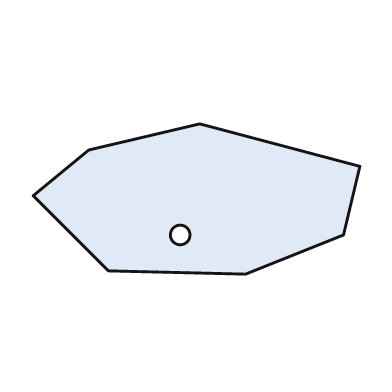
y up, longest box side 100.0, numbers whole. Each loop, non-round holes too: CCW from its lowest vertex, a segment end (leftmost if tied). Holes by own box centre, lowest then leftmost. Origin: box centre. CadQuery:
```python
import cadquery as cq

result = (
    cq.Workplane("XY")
    .moveTo(15.0, -23.0)
    .lineTo(45.0, -11.0)
    .lineTo(50.0, 10.0)
    .lineTo(1.0, 23.0)
    .lineTo(-33.0, 15.0)
    .lineTo(-50.0, 1.0)
    .lineTo(-27.0, -22.0)
    .close()
    .moveTo(-5.0, -11.0)
    .circle(3.0)
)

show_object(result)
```